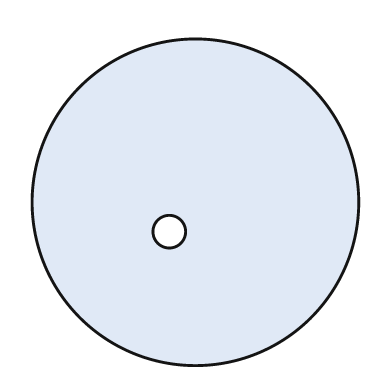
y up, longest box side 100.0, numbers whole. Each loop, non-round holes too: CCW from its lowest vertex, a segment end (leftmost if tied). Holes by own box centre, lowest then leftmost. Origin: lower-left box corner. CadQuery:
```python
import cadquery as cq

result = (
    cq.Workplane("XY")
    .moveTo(50.0, 50.0)
    .circle(50.0)
    .moveTo(42.0, 41.0)
    .circle(5.0)
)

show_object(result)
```